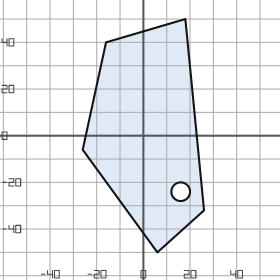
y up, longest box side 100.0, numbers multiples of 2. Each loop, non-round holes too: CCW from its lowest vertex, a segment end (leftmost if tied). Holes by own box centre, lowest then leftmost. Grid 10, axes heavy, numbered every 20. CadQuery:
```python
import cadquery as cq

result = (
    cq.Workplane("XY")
    .moveTo(6.0, -50.0)
    .lineTo(26.0, -32.0)
    .lineTo(18.0, 50.0)
    .lineTo(-16.0, 40.0)
    .lineTo(-26.0, -6.0)
    .close()
    .moveTo(16.0, -24.0)
    .circle(4.0)
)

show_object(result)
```